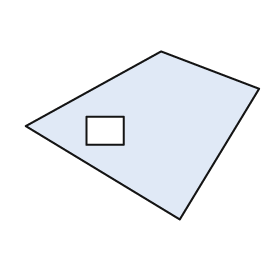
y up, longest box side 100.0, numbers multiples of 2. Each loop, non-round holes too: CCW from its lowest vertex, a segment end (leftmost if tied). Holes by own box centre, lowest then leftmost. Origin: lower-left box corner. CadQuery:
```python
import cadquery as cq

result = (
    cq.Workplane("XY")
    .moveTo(66.0, 0.0)
    .lineTo(100.0, 56.0)
    .lineTo(58.0, 72.0)
    .lineTo(0.0, 40.0)
    .close()
    .moveTo(26.0, 32.0)
    .lineTo(42.0, 32.0)
    .lineTo(42.0, 44.0)
    .lineTo(26.0, 44.0)
    .close()
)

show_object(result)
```